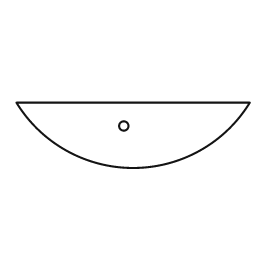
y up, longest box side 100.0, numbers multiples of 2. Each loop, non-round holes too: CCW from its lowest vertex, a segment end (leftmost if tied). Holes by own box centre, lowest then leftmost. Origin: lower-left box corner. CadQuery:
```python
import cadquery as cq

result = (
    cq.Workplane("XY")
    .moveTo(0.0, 28.0)
    .threePointArc((50.0, 0.0), (100.0, 28.0))
    .close()
    .moveTo(46.0, 18.0)
    .circle(2.0)
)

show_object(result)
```